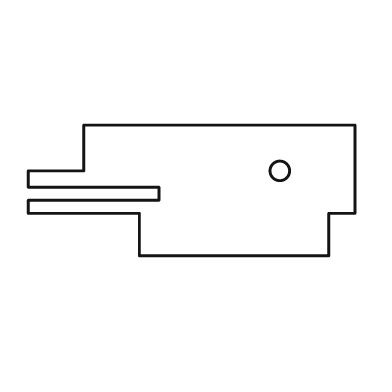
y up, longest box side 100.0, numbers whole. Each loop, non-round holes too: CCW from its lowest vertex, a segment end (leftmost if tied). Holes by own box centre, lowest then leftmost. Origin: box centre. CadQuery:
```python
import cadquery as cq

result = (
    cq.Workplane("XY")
    .moveTo(-16.0, -20.0)
    .lineTo(42.0, -20.0)
    .lineTo(42.0, -7.0)
    .lineTo(50.0, -7.0)
    .lineTo(50.0, 20.0)
    .lineTo(-33.0, 20.0)
    .lineTo(-33.0, 6.0)
    .lineTo(-50.0, 6.0)
    .lineTo(-50.0, 1.0)
    .lineTo(-10.0, 1.0)
    .lineTo(-10.0, -3.0)
    .lineTo(-50.0, -3.0)
    .lineTo(-50.0, -7.0)
    .lineTo(-16.0, -7.0)
    .close()
    .moveTo(27.0, 6.0)
    .circle(3.0)
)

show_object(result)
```